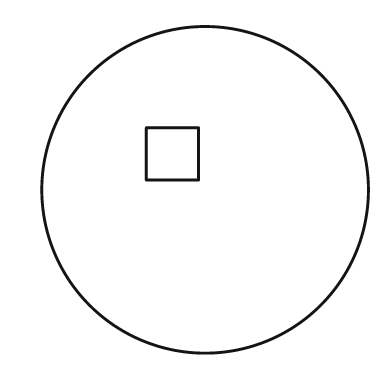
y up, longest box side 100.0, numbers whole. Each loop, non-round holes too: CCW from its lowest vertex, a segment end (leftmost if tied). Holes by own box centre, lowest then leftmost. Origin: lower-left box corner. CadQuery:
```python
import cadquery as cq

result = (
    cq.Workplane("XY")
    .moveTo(50.0, 50.0)
    .circle(50.0)
    .moveTo(32.0, 53.0)
    .lineTo(48.0, 53.0)
    .lineTo(48.0, 69.0)
    .lineTo(32.0, 69.0)
    .close()
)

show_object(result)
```